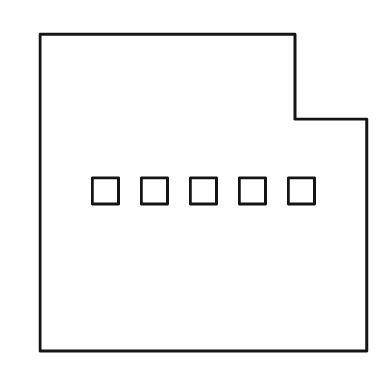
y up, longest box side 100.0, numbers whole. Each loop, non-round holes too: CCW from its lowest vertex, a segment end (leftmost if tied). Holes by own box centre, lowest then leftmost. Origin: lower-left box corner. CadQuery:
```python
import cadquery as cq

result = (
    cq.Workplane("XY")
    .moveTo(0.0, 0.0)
    .lineTo(100.0, 0.0)
    .lineTo(100.0, 71.0)
    .lineTo(78.0, 71.0)
    .lineTo(78.0, 97.0)
    .lineTo(0.0, 97.0)
    .close()
    .moveTo(16.0, 45.0)
    .lineTo(24.0, 45.0)
    .lineTo(24.0, 53.0)
    .lineTo(16.0, 53.0)
    .close()
    .moveTo(31.0, 45.0)
    .lineTo(39.0, 45.0)
    .lineTo(39.0, 53.0)
    .lineTo(31.0, 53.0)
    .close()
    .moveTo(46.0, 45.0)
    .lineTo(54.0, 45.0)
    .lineTo(54.0, 53.0)
    .lineTo(46.0, 53.0)
    .close()
    .moveTo(61.0, 45.0)
    .lineTo(69.0, 45.0)
    .lineTo(69.0, 53.0)
    .lineTo(61.0, 53.0)
    .close()
    .moveTo(76.0, 45.0)
    .lineTo(84.0, 45.0)
    .lineTo(84.0, 53.0)
    .lineTo(76.0, 53.0)
    .close()
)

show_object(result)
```